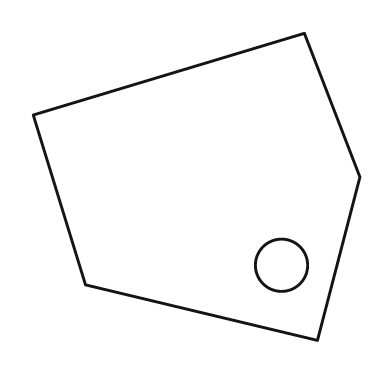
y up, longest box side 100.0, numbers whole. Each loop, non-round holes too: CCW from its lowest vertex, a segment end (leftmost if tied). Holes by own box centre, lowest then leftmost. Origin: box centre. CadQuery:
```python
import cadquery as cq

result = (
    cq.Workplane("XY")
    .moveTo(37.0, -47.0)
    .lineTo(50.0, 3.0)
    .lineTo(33.0, 47.0)
    .lineTo(-50.0, 22.0)
    .lineTo(-34.0, -30.0)
    .close()
    .moveTo(26.0, -24.0)
    .circle(8.0)
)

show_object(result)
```